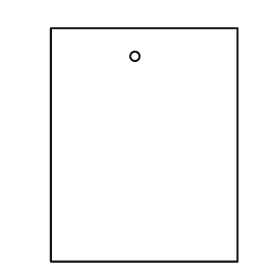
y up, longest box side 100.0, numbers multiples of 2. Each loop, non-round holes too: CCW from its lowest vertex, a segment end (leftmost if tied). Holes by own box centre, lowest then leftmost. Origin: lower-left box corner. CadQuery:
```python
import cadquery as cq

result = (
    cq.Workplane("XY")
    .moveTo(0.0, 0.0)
    .lineTo(80.0, 0.0)
    .lineTo(80.0, 100.0)
    .lineTo(0.0, 100.0)
    .close()
    .moveTo(36.0, 88.0)
    .circle(2.0)
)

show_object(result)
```